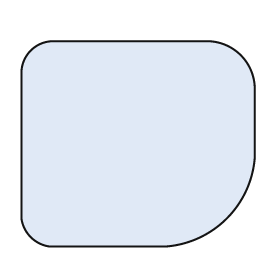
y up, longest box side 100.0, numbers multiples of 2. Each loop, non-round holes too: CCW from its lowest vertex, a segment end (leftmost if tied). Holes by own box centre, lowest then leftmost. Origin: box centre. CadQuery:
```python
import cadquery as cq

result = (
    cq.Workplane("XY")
    .moveTo(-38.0, -44.0)
    .lineTo(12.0, -44.0)
    .threePointArc((38.0, -32.0), (50.0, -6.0))
    .lineTo(50.0, 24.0)
    .threePointArc((44.0, 38.0), (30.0, 44.0))
    .lineTo(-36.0, 44.0)
    .threePointArc((-46.0, 40.0), (-50.0, 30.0))
    .lineTo(-50.0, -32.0)
    .threePointArc((-46.0, -40.0), (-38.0, -44.0))
    .close()
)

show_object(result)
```